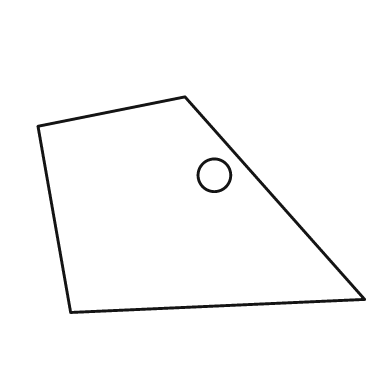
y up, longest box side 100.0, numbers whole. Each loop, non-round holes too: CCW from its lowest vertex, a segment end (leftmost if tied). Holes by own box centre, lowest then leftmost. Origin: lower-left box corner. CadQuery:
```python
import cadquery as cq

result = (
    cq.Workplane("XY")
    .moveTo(10.0, 0.0)
    .lineTo(100.0, 4.0)
    .lineTo(45.0, 66.0)
    .lineTo(0.0, 57.0)
    .close()
    .moveTo(54.0, 42.0)
    .circle(5.0)
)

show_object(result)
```